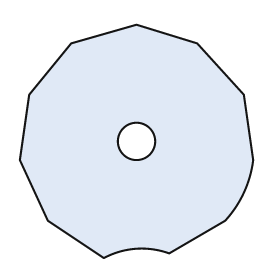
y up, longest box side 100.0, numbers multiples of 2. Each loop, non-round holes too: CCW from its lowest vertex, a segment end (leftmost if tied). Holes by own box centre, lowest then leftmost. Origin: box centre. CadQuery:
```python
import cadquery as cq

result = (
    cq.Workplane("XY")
    .moveTo(-14.0, -50.0)
    .threePointArc((0.0, -46.0), (14.0, -48.0))
    .lineTo(38.0, -34.0)
    .threePointArc((46.0, -22.0), (50.0, -8.0))
    .lineTo(46.0, 20.0)
    .lineTo(26.0, 42.0)
    .lineTo(0.0, 50.0)
    .lineTo(-28.0, 42.0)
    .lineTo(-46.0, 20.0)
    .lineTo(-50.0, -8.0)
    .lineTo(-38.0, -34.0)
    .close()
    .moveTo(0.0, 0.0)
    .circle(8.0)
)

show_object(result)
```